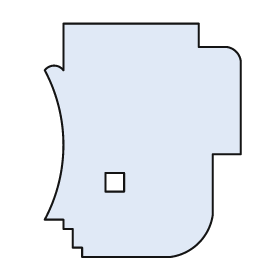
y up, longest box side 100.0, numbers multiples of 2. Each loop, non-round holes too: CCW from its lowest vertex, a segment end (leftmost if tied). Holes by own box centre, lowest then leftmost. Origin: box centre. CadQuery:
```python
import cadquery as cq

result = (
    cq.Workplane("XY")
    .moveTo(-26.0, -50.0)
    .lineTo(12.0, -50.0)
    .threePointArc((24.0, -44.0), (30.0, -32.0))
    .lineTo(30.0, -6.0)
    .lineTo(42.0, -6.0)
    .lineTo(42.0, 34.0)
    .threePointArc((40.0, 38.0), (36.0, 40.0))
    .lineTo(24.0, 40.0)
    .lineTo(24.0, 50.0)
    .lineTo(-34.0, 50.0)
    .lineTo(-34.0, 30.0)
    .threePointArc((-38.0, 32.0), (-42.0, 30.0))
    .threePointArc((-34.0, -2.0), (-42.0, -34.0))
    .lineTo(-34.0, -34.0)
    .lineTo(-34.0, -38.0)
    .lineTo(-30.0, -38.0)
    .lineTo(-30.0, -46.0)
    .lineTo(-26.0, -46.0)
    .close()
    .moveTo(-16.0, -22.0)
    .lineTo(-8.0, -22.0)
    .lineTo(-8.0, -14.0)
    .lineTo(-16.0, -14.0)
    .close()
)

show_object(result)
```